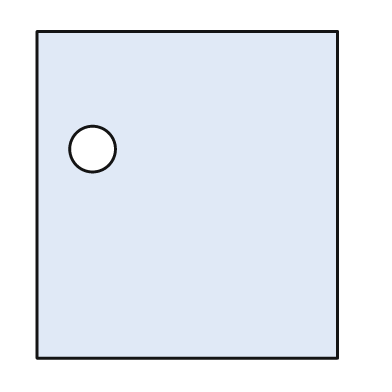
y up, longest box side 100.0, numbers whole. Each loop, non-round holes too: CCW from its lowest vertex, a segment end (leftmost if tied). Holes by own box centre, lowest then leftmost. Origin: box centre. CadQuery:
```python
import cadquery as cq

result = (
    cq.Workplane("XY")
    .moveTo(-46.0, -50.0)
    .lineTo(46.0, -50.0)
    .lineTo(46.0, 50.0)
    .lineTo(-46.0, 50.0)
    .close()
    .moveTo(-29.0, 14.0)
    .circle(7.0)
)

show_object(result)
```